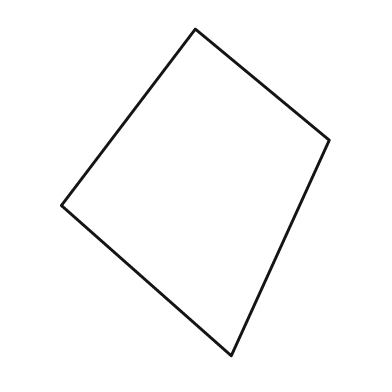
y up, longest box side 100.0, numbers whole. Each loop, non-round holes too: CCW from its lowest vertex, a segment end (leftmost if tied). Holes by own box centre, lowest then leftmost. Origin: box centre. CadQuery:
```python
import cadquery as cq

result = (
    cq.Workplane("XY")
    .moveTo(11.0, -50.0)
    .lineTo(41.0, 16.0)
    .lineTo(0.0, 50.0)
    .lineTo(-41.0, -4.0)
    .close()
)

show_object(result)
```